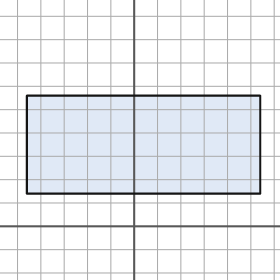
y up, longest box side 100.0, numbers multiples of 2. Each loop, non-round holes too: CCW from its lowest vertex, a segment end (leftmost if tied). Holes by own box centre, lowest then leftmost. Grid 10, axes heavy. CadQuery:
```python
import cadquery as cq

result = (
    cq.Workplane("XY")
    .moveTo(-46.0, 14.0)
    .lineTo(54.0, 14.0)
    .lineTo(54.0, 56.0)
    .lineTo(-46.0, 56.0)
    .close()
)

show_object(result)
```